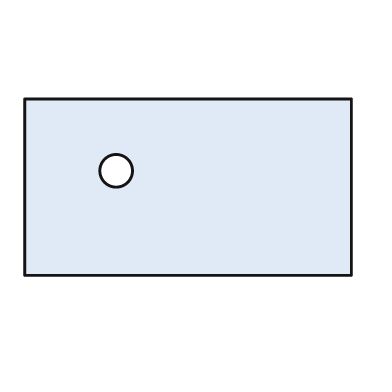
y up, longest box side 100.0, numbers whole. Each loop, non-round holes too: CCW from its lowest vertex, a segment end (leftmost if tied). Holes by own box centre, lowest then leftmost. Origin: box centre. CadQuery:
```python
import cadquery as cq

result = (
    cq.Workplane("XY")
    .moveTo(-50.0, -27.0)
    .lineTo(50.0, -27.0)
    .lineTo(50.0, 27.0)
    .lineTo(-50.0, 27.0)
    .close()
    .moveTo(-22.0, 5.0)
    .circle(5.0)
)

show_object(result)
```